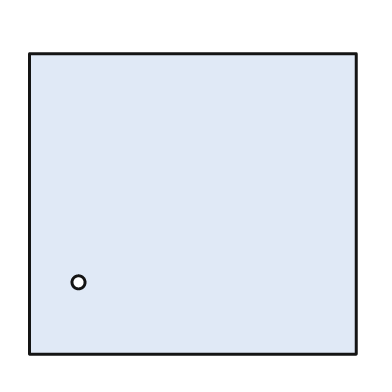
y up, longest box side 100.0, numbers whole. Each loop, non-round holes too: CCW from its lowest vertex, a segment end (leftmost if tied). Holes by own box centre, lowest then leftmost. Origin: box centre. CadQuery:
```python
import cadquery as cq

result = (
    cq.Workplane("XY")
    .moveTo(-50.0, -46.0)
    .lineTo(50.0, -46.0)
    .lineTo(50.0, 46.0)
    .lineTo(-50.0, 46.0)
    .close()
    .moveTo(-35.0, -24.0)
    .circle(2.0)
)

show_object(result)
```